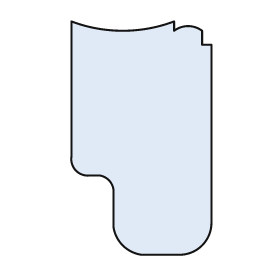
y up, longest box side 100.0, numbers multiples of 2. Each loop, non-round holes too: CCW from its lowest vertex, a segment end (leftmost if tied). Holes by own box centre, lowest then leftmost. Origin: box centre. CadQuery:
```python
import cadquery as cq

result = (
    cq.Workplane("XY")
    .moveTo(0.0, -50.0)
    .lineTo(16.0, -50.0)
    .threePointArc((26.0, -46.0), (30.0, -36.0))
    .lineTo(30.0, 40.0)
    .lineTo(26.0, 40.0)
    .lineTo(26.0, 46.0)
    .threePointArc((20.0, 48.0), (14.0, 46.0))
    .lineTo(14.0, 50.0)
    .threePointArc((-8.0, 46.0), (-30.0, 50.0))
    .lineTo(-30.0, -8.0)
    .threePointArc((-28.0, -14.0), (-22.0, -16.0))
    .lineTo(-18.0, -16.0)
    .threePointArc((-14.0, -18.0), (-12.0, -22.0))
    .lineTo(-12.0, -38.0)
    .threePointArc((-8.0, -46.0), (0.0, -50.0))
    .close()
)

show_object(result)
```